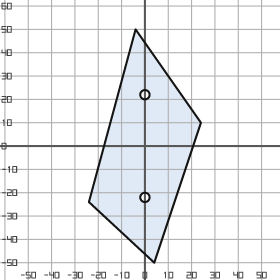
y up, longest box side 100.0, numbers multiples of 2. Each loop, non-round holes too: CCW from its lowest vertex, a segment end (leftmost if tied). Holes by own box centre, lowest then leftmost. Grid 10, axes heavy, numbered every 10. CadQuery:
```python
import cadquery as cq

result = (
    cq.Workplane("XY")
    .moveTo(4.0, -50.0)
    .lineTo(24.0, 10.0)
    .lineTo(-4.0, 50.0)
    .lineTo(-24.0, -24.0)
    .close()
    .moveTo(0.0, -22.0)
    .circle(2.0)
    .moveTo(0.0, 22.0)
    .circle(2.0)
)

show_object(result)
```